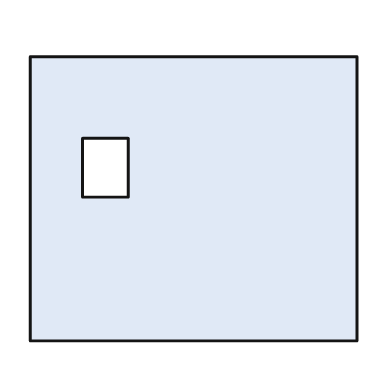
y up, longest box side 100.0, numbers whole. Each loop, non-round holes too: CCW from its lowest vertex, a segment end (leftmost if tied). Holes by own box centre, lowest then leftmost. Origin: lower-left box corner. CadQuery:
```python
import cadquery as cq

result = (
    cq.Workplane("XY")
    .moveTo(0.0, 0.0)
    .lineTo(100.0, 0.0)
    .lineTo(100.0, 87.0)
    .lineTo(0.0, 87.0)
    .close()
    .moveTo(16.0, 44.0)
    .lineTo(30.0, 44.0)
    .lineTo(30.0, 62.0)
    .lineTo(16.0, 62.0)
    .close()
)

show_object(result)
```